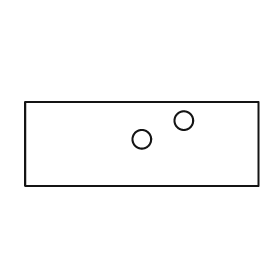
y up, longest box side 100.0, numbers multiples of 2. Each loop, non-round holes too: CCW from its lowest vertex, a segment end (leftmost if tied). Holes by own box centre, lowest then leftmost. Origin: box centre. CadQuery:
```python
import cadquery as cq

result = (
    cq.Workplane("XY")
    .moveTo(-50.0, -18.0)
    .lineTo(50.0, -18.0)
    .lineTo(50.0, 18.0)
    .lineTo(-50.0, 18.0)
    .close()
    .moveTo(0.0, 2.0)
    .circle(4.0)
    .moveTo(18.0, 10.0)
    .circle(4.0)
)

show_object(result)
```